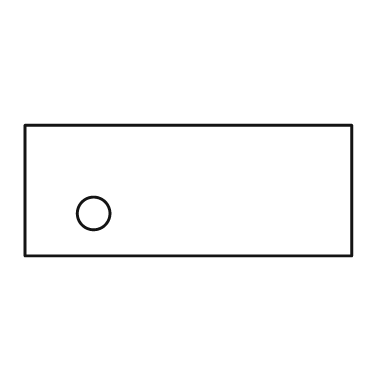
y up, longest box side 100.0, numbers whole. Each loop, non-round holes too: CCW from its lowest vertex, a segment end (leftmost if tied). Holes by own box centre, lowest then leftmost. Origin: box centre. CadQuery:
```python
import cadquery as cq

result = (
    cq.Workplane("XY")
    .moveTo(-50.0, -20.0)
    .lineTo(50.0, -20.0)
    .lineTo(50.0, 20.0)
    .lineTo(-50.0, 20.0)
    .close()
    .moveTo(-29.0, -7.0)
    .circle(5.0)
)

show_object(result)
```